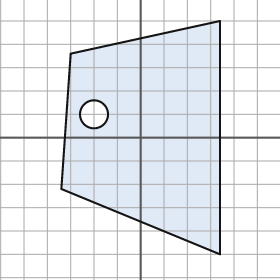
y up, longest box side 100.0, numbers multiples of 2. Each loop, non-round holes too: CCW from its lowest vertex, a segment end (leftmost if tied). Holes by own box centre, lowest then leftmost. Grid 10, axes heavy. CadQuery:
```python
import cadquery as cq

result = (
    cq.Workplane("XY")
    .moveTo(34.0, -50.0)
    .lineTo(34.0, 50.0)
    .lineTo(-30.0, 36.0)
    .lineTo(-34.0, -22.0)
    .close()
    .moveTo(-20.0, 10.0)
    .circle(6.0)
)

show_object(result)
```